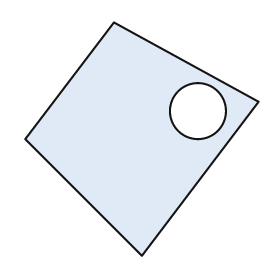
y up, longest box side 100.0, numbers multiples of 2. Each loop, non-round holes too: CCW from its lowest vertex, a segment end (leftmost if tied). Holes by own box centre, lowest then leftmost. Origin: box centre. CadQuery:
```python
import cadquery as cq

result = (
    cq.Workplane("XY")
    .moveTo(0.0, -50.0)
    .lineTo(50.0, 16.0)
    .lineTo(-12.0, 50.0)
    .lineTo(-50.0, 0.0)
    .close()
    .moveTo(24.0, 12.0)
    .circle(12.0)
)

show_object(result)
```